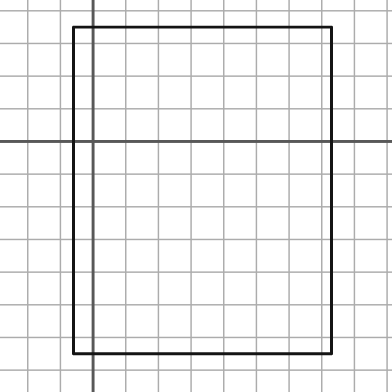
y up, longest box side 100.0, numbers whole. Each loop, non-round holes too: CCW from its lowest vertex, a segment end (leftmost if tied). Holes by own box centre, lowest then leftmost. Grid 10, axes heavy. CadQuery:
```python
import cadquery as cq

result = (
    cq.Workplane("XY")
    .moveTo(-6.0, -65.0)
    .lineTo(73.0, -65.0)
    .lineTo(73.0, 35.0)
    .lineTo(-6.0, 35.0)
    .close()
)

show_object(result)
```